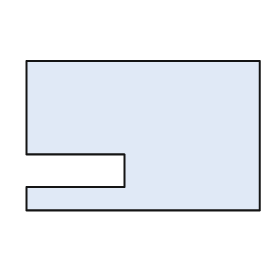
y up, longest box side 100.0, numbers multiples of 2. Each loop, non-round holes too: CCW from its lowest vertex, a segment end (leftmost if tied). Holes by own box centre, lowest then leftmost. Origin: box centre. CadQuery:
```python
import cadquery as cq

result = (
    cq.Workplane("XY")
    .moveTo(-50.0, -32.0)
    .lineTo(50.0, -32.0)
    .lineTo(50.0, 32.0)
    .lineTo(-50.0, 32.0)
    .lineTo(-50.0, -8.0)
    .lineTo(-8.0, -8.0)
    .lineTo(-8.0, -22.0)
    .lineTo(-50.0, -22.0)
    .close()
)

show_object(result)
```